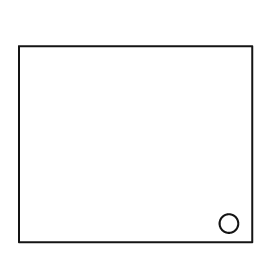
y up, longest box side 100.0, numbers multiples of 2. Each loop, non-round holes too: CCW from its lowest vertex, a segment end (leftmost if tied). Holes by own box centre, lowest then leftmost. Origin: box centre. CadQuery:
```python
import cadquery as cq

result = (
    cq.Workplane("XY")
    .moveTo(-50.0, -42.0)
    .lineTo(50.0, -42.0)
    .lineTo(50.0, 42.0)
    .lineTo(-50.0, 42.0)
    .close()
    .moveTo(40.0, -34.0)
    .circle(4.0)
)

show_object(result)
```